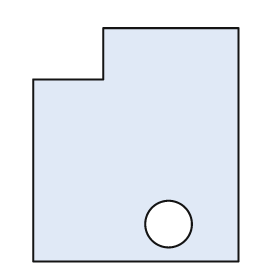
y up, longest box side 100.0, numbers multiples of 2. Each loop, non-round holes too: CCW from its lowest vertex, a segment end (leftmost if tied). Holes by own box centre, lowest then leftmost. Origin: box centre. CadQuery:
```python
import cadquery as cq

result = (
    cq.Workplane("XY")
    .moveTo(-44.0, -50.0)
    .lineTo(44.0, -50.0)
    .lineTo(44.0, 50.0)
    .lineTo(-14.0, 50.0)
    .lineTo(-14.0, 28.0)
    .lineTo(-44.0, 28.0)
    .close()
    .moveTo(14.0, -34.0)
    .circle(10.0)
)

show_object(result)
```